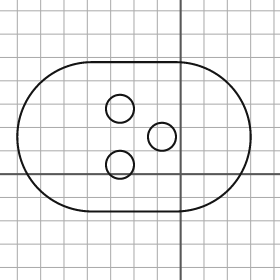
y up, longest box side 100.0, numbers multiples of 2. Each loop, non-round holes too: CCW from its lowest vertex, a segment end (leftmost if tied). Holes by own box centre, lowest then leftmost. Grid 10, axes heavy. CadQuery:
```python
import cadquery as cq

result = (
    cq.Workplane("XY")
    .moveTo(-38.0, -16.0)
    .lineTo(-2.0, -16.0)
    .threePointArc((30.0, 16.0), (-2.0, 48.0))
    .lineTo(-38.0, 48.0)
    .threePointArc((-70.0, 16.0), (-38.0, -16.0))
    .close()
    .moveTo(-26.0, 4.0)
    .circle(6.0)
    .moveTo(-8.0, 16.0)
    .circle(6.0)
    .moveTo(-26.0, 28.0)
    .circle(6.0)
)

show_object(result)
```